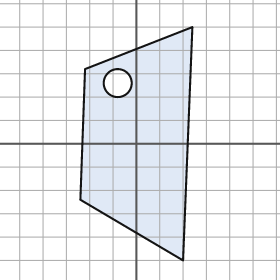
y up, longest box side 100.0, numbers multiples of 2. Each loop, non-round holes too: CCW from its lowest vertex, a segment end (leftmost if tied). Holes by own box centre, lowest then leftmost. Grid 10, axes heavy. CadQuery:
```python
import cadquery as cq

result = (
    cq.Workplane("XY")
    .moveTo(20.0, -50.0)
    .lineTo(24.0, 50.0)
    .lineTo(-22.0, 32.0)
    .lineTo(-24.0, -24.0)
    .close()
    .moveTo(-8.0, 26.0)
    .circle(6.0)
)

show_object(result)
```